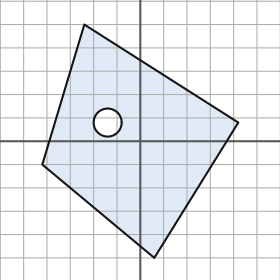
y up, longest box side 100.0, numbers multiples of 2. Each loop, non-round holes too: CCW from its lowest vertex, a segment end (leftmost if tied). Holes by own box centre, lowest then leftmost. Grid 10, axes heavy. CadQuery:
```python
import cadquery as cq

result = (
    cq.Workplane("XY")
    .moveTo(6.0, -50.0)
    .lineTo(42.0, 8.0)
    .lineTo(-24.0, 50.0)
    .lineTo(-42.0, -10.0)
    .close()
    .moveTo(-14.0, 8.0)
    .circle(6.0)
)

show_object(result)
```